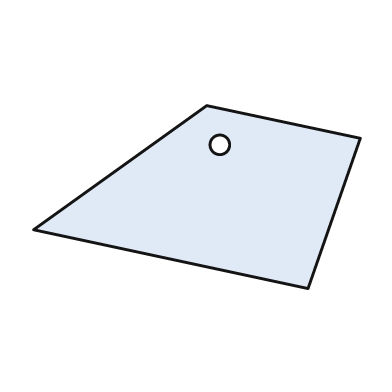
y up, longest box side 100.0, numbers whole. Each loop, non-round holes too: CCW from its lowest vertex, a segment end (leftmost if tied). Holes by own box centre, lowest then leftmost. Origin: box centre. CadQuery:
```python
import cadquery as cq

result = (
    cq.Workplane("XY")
    .moveTo(34.0, -28.0)
    .lineTo(50.0, 18.0)
    .lineTo(3.0, 28.0)
    .lineTo(-50.0, -10.0)
    .close()
    .moveTo(7.0, 16.0)
    .circle(3.0)
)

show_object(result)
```